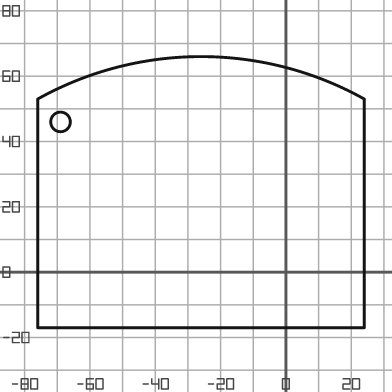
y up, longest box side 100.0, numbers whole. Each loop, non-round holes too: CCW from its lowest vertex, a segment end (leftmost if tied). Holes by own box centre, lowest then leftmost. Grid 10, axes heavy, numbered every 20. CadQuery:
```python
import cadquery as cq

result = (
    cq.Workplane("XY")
    .moveTo(-76.0, -17.0)
    .lineTo(24.0, -17.0)
    .lineTo(24.0, 53.0)
    .threePointArc((-26.0, 66.0), (-76.0, 53.0))
    .close()
    .moveTo(-69.0, 46.0)
    .circle(3.0)
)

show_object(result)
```